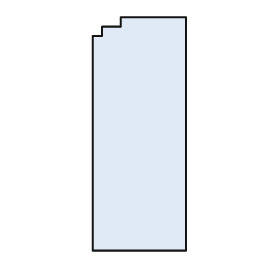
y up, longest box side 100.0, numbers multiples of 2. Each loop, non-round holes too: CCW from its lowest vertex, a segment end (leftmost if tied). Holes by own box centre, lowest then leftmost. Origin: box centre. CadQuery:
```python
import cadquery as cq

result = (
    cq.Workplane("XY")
    .moveTo(-20.0, -50.0)
    .lineTo(20.0, -50.0)
    .lineTo(20.0, 50.0)
    .lineTo(-8.0, 50.0)
    .lineTo(-8.0, 46.0)
    .lineTo(-16.0, 46.0)
    .lineTo(-16.0, 42.0)
    .lineTo(-20.0, 42.0)
    .close()
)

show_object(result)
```